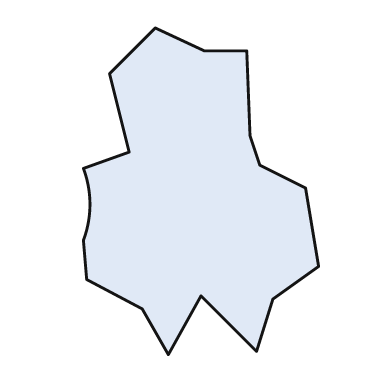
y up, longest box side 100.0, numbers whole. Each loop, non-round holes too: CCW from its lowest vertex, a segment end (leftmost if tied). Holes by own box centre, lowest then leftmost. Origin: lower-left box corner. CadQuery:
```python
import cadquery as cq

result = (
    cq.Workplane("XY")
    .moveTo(26.0, 0.0)
    .lineTo(36.0, 18.0)
    .lineTo(53.0, 1.0)
    .lineTo(58.0, 17.0)
    .lineTo(72.0, 27.0)
    .lineTo(68.0, 51.0)
    .lineTo(54.0, 58.0)
    .lineTo(51.0, 67.0)
    .lineTo(50.0, 93.0)
    .lineTo(37.0, 93.0)
    .lineTo(22.0, 100.0)
    .lineTo(8.0, 86.0)
    .lineTo(14.0, 62.0)
    .lineTo(0.0, 57.0)
    .threePointArc((2.0, 46.0), (0.0, 35.0))
    .lineTo(1.0, 23.0)
    .lineTo(18.0, 14.0)
    .close()
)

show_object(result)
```